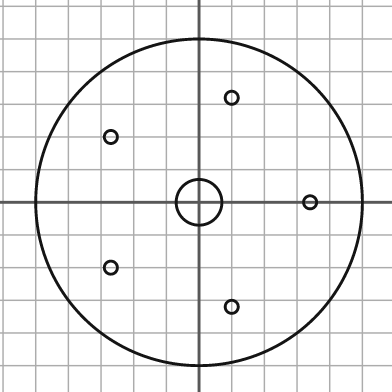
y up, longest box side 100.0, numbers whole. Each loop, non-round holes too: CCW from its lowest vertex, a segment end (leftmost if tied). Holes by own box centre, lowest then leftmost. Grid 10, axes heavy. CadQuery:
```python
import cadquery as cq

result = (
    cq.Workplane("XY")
    .moveTo(0.0, 0.0)
    .circle(50.0)
    .moveTo(10.0, -32.0)
    .circle(2.0)
    .moveTo(-27.0, -20.0)
    .circle(2.0)
    .moveTo(0.0, 0.0)
    .circle(7.0)
    .moveTo(34.0, 0.0)
    .circle(2.0)
    .moveTo(-27.0, 20.0)
    .circle(2.0)
    .moveTo(10.0, 32.0)
    .circle(2.0)
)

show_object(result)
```